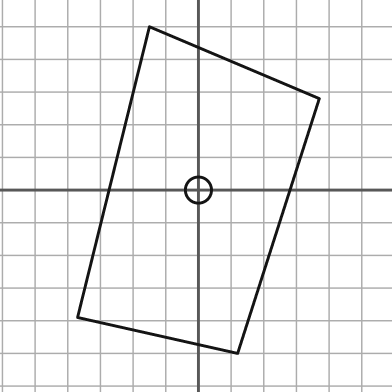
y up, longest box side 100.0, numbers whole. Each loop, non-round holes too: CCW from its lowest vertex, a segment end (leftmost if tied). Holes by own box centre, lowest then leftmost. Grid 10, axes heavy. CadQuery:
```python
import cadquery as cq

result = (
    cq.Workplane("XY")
    .moveTo(12.0, -50.0)
    .lineTo(37.0, 28.0)
    .lineTo(-15.0, 50.0)
    .lineTo(-37.0, -39.0)
    .close()
    .moveTo(0.0, 0.0)
    .circle(4.0)
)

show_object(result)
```